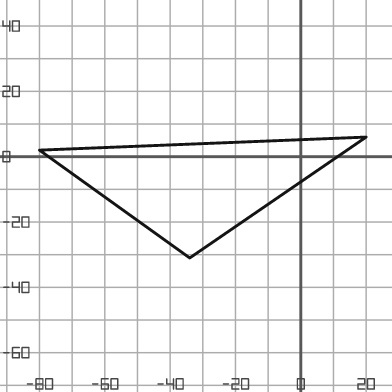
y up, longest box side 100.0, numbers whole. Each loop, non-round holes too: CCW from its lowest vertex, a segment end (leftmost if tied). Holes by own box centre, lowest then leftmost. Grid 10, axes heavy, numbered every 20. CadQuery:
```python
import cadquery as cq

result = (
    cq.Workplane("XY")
    .moveTo(-34.0, -31.0)
    .lineTo(20.0, 6.0)
    .lineTo(-80.0, 2.0)
    .close()
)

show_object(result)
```